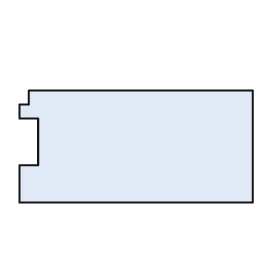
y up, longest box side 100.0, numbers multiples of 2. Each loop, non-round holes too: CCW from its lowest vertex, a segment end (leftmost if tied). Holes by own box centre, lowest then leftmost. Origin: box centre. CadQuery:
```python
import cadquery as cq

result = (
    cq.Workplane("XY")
    .moveTo(-50.0, -24.0)
    .lineTo(50.0, -24.0)
    .lineTo(50.0, 24.0)
    .lineTo(-46.0, 24.0)
    .lineTo(-46.0, 18.0)
    .lineTo(-50.0, 18.0)
    .lineTo(-50.0, 12.0)
    .lineTo(-42.0, 12.0)
    .lineTo(-42.0, -8.0)
    .lineTo(-50.0, -8.0)
    .close()
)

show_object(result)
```